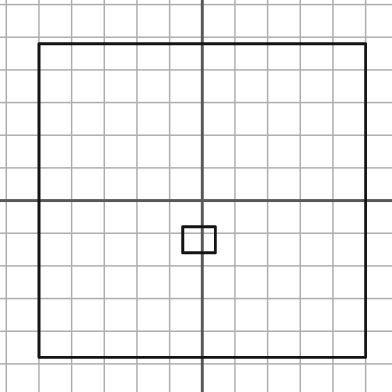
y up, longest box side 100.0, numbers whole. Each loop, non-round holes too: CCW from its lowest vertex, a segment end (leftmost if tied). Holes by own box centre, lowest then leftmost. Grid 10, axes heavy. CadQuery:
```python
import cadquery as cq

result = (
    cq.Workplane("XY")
    .moveTo(-50.0, -48.0)
    .lineTo(50.0, -48.0)
    .lineTo(50.0, 48.0)
    .lineTo(-50.0, 48.0)
    .close()
    .moveTo(-6.0, -16.0)
    .lineTo(4.0, -16.0)
    .lineTo(4.0, -8.0)
    .lineTo(-6.0, -8.0)
    .close()
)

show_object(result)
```